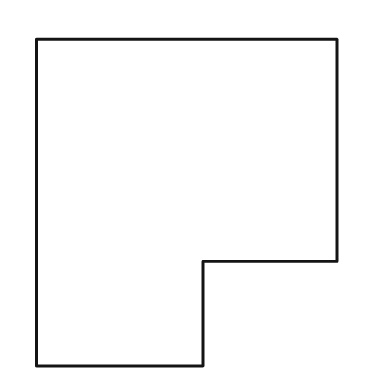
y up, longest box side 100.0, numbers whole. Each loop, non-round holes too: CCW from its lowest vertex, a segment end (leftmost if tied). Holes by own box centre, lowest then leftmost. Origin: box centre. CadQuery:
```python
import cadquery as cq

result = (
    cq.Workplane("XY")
    .moveTo(-46.0, -50.0)
    .lineTo(5.0, -50.0)
    .lineTo(5.0, -18.0)
    .lineTo(46.0, -18.0)
    .lineTo(46.0, 50.0)
    .lineTo(-46.0, 50.0)
    .close()
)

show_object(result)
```